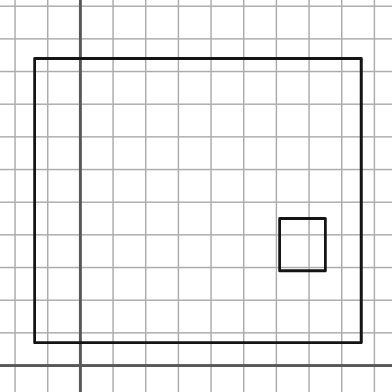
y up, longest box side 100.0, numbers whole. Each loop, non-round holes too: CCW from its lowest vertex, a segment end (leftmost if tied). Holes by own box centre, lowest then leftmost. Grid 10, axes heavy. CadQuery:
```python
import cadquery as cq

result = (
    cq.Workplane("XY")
    .moveTo(-14.0, 7.0)
    .lineTo(86.0, 7.0)
    .lineTo(86.0, 94.0)
    .lineTo(-14.0, 94.0)
    .close()
    .moveTo(61.0, 29.0)
    .lineTo(75.0, 29.0)
    .lineTo(75.0, 45.0)
    .lineTo(61.0, 45.0)
    .close()
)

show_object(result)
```